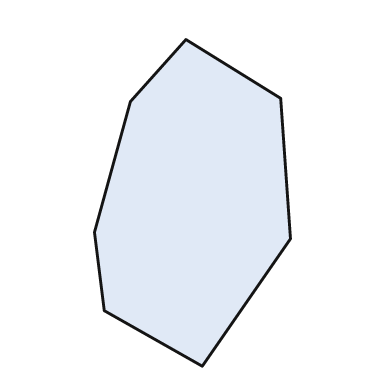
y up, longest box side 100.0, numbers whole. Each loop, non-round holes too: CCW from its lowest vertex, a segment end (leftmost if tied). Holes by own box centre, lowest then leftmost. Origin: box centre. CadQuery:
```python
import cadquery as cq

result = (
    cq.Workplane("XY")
    .moveTo(3.0, -50.0)
    .lineTo(30.0, -11.0)
    .lineTo(27.0, 32.0)
    .lineTo(-2.0, 50.0)
    .lineTo(-19.0, 31.0)
    .lineTo(-30.0, -9.0)
    .lineTo(-27.0, -33.0)
    .close()
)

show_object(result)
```